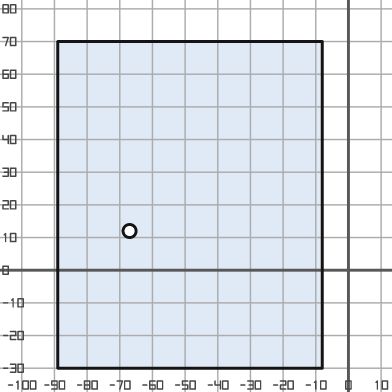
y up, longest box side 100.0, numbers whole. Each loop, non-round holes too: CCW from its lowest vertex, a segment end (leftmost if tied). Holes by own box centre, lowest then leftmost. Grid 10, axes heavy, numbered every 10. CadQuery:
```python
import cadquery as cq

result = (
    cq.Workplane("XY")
    .moveTo(-89.0, -30.0)
    .lineTo(-8.0, -30.0)
    .lineTo(-8.0, 70.0)
    .lineTo(-89.0, 70.0)
    .close()
    .moveTo(-67.0, 12.0)
    .circle(2.0)
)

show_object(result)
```